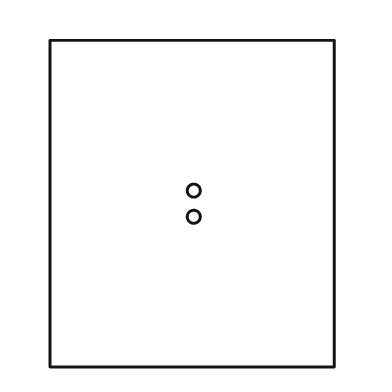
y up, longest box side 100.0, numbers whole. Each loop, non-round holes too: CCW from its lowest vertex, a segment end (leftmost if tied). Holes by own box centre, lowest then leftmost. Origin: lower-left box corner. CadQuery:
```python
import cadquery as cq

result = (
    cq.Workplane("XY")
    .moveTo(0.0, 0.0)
    .lineTo(87.0, 0.0)
    .lineTo(87.0, 100.0)
    .lineTo(0.0, 100.0)
    .close()
    .moveTo(44.0, 46.0)
    .circle(2.0)
    .moveTo(44.0, 54.0)
    .circle(2.0)
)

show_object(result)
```